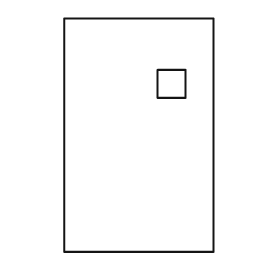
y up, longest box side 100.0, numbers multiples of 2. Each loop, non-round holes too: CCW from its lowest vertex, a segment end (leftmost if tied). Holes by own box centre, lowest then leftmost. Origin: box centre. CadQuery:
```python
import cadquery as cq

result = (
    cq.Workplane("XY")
    .moveTo(-32.0, -50.0)
    .lineTo(32.0, -50.0)
    .lineTo(32.0, 50.0)
    .lineTo(-32.0, 50.0)
    .close()
    .moveTo(8.0, 16.0)
    .lineTo(20.0, 16.0)
    .lineTo(20.0, 28.0)
    .lineTo(8.0, 28.0)
    .close()
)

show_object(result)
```